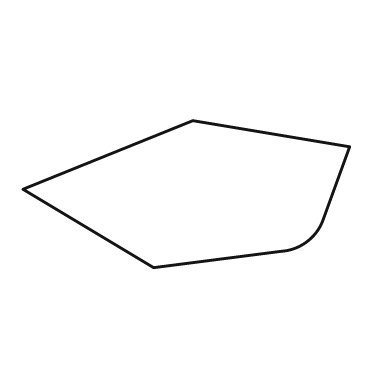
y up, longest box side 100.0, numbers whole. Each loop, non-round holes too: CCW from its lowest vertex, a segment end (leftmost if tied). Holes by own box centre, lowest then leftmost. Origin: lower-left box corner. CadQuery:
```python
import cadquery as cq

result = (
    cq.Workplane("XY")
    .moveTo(40.0, 0.0)
    .lineTo(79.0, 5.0)
    .threePointArc((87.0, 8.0), (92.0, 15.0))
    .lineTo(100.0, 37.0)
    .lineTo(52.0, 45.0)
    .lineTo(0.0, 24.0)
    .close()
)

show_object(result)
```